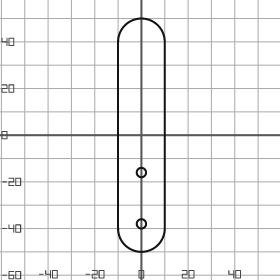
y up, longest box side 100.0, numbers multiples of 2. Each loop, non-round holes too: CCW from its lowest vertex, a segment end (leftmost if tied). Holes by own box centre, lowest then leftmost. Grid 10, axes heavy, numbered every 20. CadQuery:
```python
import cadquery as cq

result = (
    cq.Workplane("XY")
    .moveTo(-10.0, -40.0)
    .threePointArc((0.0, -50.0), (10.0, -40.0))
    .lineTo(10.0, 40.0)
    .threePointArc((0.0, 50.0), (-10.0, 40.0))
    .close()
    .moveTo(0.0, -38.0)
    .circle(2.0)
    .moveTo(0.0, -16.0)
    .circle(2.0)
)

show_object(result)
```